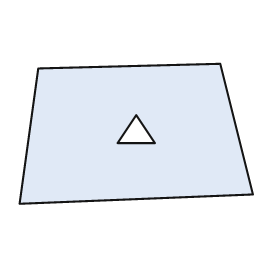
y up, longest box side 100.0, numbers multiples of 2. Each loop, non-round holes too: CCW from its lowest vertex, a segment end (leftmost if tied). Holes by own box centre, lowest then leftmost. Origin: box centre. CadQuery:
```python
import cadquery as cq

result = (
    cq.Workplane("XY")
    .moveTo(-50.0, -30.0)
    .lineTo(50.0, -26.0)
    .lineTo(36.0, 30.0)
    .lineTo(-42.0, 28.0)
    .close()
    .moveTo(-8.0, -4.0)
    .lineTo(8.0, -4.0)
    .lineTo(0.0, 8.0)
    .close()
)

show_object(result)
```